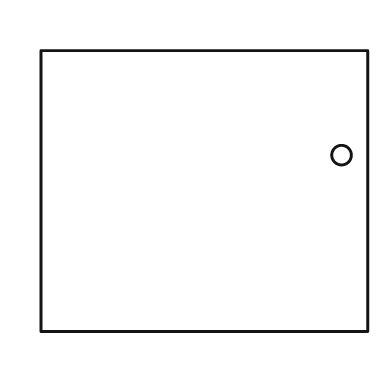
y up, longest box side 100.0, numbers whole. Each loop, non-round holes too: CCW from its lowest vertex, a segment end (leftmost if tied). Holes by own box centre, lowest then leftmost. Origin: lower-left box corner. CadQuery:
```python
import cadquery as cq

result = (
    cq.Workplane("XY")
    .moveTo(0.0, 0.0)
    .lineTo(100.0, 0.0)
    .lineTo(100.0, 86.0)
    .lineTo(0.0, 86.0)
    .close()
    .moveTo(92.0, 54.0)
    .circle(3.0)
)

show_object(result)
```